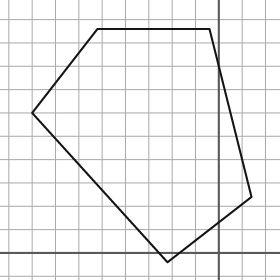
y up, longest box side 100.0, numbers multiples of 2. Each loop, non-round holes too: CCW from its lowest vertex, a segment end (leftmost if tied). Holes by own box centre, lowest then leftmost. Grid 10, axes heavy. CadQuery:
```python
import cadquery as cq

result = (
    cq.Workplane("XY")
    .moveTo(-22.0, -4.0)
    .lineTo(14.0, 24.0)
    .lineTo(-4.0, 96.0)
    .lineTo(-52.0, 96.0)
    .lineTo(-80.0, 60.0)
    .close()
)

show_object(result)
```